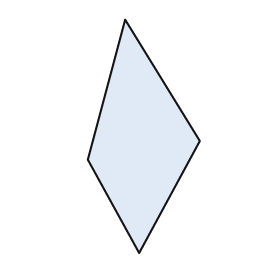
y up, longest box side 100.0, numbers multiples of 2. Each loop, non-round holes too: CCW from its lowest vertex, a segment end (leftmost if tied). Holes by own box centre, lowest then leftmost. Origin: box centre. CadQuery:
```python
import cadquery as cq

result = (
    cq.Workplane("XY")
    .moveTo(-2.0, -50.0)
    .lineTo(24.0, -2.0)
    .lineTo(-8.0, 50.0)
    .lineTo(-24.0, -10.0)
    .close()
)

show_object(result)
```